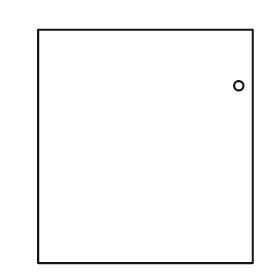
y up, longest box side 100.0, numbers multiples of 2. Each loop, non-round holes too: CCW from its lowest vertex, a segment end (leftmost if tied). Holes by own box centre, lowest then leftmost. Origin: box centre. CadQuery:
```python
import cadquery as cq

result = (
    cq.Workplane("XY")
    .moveTo(-46.0, -50.0)
    .lineTo(46.0, -50.0)
    .lineTo(46.0, 50.0)
    .lineTo(-46.0, 50.0)
    .close()
    .moveTo(40.0, 26.0)
    .circle(2.0)
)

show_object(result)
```